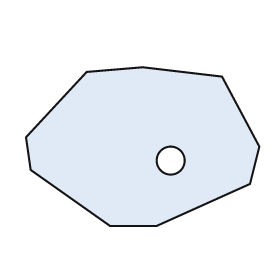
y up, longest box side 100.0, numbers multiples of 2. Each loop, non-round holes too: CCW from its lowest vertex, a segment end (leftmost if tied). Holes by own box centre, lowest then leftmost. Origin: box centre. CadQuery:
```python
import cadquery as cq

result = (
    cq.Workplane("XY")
    .moveTo(-14.0, -34.0)
    .lineTo(6.0, -34.0)
    .lineTo(46.0, -16.0)
    .lineTo(50.0, 0.0)
    .lineTo(34.0, 30.0)
    .lineTo(0.0, 34.0)
    .lineTo(-24.0, 32.0)
    .lineTo(-50.0, 4.0)
    .lineTo(-48.0, -10.0)
    .close()
    .moveTo(12.0, -6.0)
    .circle(6.0)
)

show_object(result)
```